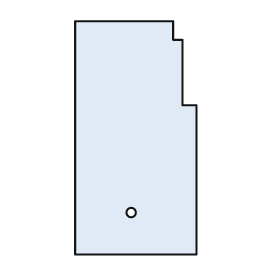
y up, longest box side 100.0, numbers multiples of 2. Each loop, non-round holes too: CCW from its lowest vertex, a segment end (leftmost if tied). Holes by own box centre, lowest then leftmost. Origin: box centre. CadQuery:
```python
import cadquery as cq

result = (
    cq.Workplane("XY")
    .moveTo(-26.0, -50.0)
    .lineTo(26.0, -50.0)
    .lineTo(26.0, 14.0)
    .lineTo(20.0, 14.0)
    .lineTo(20.0, 42.0)
    .lineTo(16.0, 42.0)
    .lineTo(16.0, 50.0)
    .lineTo(-26.0, 50.0)
    .close()
    .moveTo(-2.0, -32.0)
    .circle(2.0)
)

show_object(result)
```